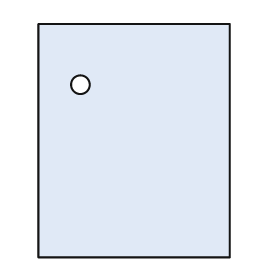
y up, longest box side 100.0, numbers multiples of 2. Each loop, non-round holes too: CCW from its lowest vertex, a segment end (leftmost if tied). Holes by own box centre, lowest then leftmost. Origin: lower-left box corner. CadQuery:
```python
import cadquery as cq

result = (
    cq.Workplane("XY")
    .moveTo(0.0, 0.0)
    .lineTo(82.0, 0.0)
    .lineTo(82.0, 100.0)
    .lineTo(0.0, 100.0)
    .close()
    .moveTo(18.0, 74.0)
    .circle(4.0)
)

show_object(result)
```